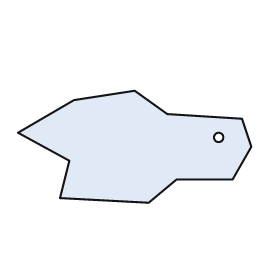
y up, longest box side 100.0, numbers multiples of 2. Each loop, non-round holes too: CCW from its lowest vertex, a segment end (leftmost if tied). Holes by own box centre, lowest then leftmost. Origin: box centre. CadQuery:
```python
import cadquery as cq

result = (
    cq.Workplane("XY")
    .moveTo(6.0, -24.0)
    .lineTo(18.0, -14.0)
    .lineTo(42.0, -14.0)
    .lineTo(50.0, 0.0)
    .lineTo(46.0, 12.0)
    .lineTo(14.0, 14.0)
    .lineTo(0.0, 24.0)
    .lineTo(-26.0, 20.0)
    .lineTo(-50.0, 6.0)
    .lineTo(-28.0, -6.0)
    .lineTo(-32.0, -22.0)
    .close()
    .moveTo(36.0, 4.0)
    .circle(2.0)
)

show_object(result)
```